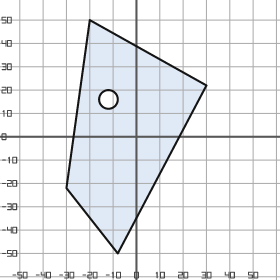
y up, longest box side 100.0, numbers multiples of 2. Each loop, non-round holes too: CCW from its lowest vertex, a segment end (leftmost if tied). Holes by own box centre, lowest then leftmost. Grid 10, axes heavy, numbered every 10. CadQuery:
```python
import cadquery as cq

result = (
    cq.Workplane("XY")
    .moveTo(-8.0, -50.0)
    .lineTo(30.0, 22.0)
    .lineTo(-20.0, 50.0)
    .lineTo(-30.0, -22.0)
    .close()
    .moveTo(-12.0, 16.0)
    .circle(4.0)
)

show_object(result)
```